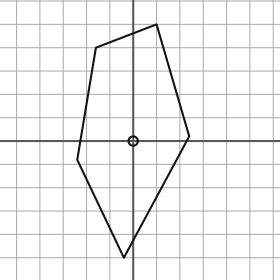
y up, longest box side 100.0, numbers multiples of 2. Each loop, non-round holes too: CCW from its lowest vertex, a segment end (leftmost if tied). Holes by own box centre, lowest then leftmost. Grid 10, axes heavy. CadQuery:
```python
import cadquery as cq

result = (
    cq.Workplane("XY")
    .moveTo(-4.0, -50.0)
    .lineTo(24.0, 2.0)
    .lineTo(10.0, 50.0)
    .lineTo(-16.0, 40.0)
    .lineTo(-24.0, -8.0)
    .close()
    .moveTo(0.0, 0.0)
    .circle(2.0)
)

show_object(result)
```